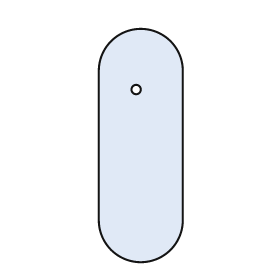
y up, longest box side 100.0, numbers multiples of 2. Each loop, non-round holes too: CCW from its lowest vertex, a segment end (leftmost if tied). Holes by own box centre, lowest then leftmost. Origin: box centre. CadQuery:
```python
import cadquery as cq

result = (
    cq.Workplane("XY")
    .moveTo(-18.0, -32.0)
    .threePointArc((0.0, -50.0), (18.0, -32.0))
    .lineTo(18.0, 32.0)
    .threePointArc((0.0, 50.0), (-18.0, 32.0))
    .close()
    .moveTo(-2.0, 24.0)
    .circle(2.0)
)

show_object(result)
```